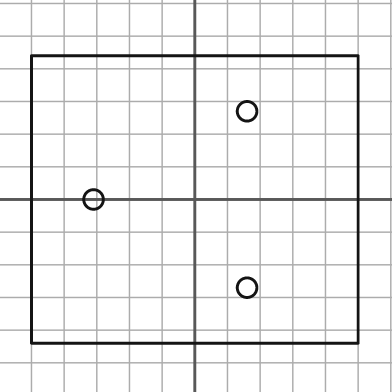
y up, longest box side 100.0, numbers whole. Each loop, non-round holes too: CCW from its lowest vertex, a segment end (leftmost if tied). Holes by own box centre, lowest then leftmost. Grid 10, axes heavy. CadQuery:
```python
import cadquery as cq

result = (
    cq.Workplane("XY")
    .moveTo(-50.0, -44.0)
    .lineTo(50.0, -44.0)
    .lineTo(50.0, 44.0)
    .lineTo(-50.0, 44.0)
    .close()
    .moveTo(16.0, -27.0)
    .circle(3.0)
    .moveTo(-31.0, 0.0)
    .circle(3.0)
    .moveTo(16.0, 27.0)
    .circle(3.0)
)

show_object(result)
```